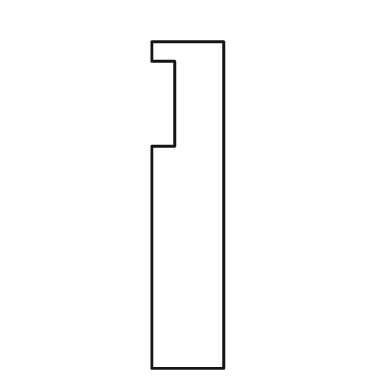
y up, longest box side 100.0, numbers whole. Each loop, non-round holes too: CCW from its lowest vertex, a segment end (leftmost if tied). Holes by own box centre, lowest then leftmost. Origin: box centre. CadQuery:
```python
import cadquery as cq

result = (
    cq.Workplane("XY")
    .moveTo(-11.0, -50.0)
    .lineTo(11.0, -50.0)
    .lineTo(11.0, 50.0)
    .lineTo(-11.0, 50.0)
    .lineTo(-11.0, 44.0)
    .lineTo(-4.0, 44.0)
    .lineTo(-4.0, 18.0)
    .lineTo(-11.0, 18.0)
    .close()
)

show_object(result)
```